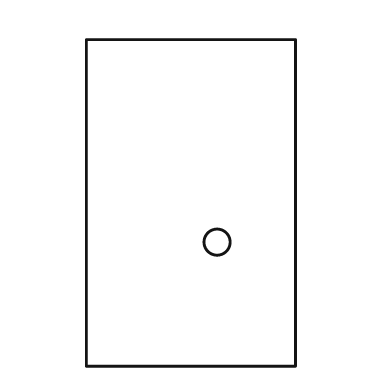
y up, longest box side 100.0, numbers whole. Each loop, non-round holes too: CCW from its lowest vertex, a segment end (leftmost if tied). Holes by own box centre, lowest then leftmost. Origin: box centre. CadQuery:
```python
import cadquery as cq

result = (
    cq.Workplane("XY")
    .moveTo(-32.0, -50.0)
    .lineTo(32.0, -50.0)
    .lineTo(32.0, 50.0)
    .lineTo(-32.0, 50.0)
    .close()
    .moveTo(8.0, -12.0)
    .circle(4.0)
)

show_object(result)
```